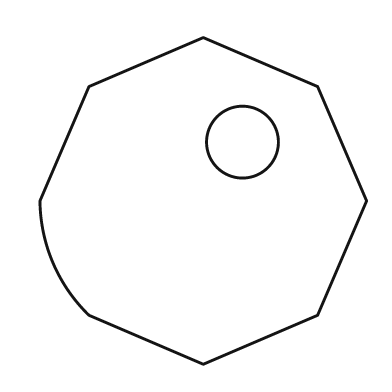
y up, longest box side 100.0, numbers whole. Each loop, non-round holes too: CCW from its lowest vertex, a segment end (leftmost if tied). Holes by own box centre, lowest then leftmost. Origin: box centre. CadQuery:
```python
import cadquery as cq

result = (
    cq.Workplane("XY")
    .moveTo(0.0, -50.0)
    .lineTo(35.0, -35.0)
    .lineTo(50.0, 0.0)
    .lineTo(35.0, 35.0)
    .lineTo(0.0, 50.0)
    .lineTo(-35.0, 35.0)
    .lineTo(-50.0, 0.0)
    .threePointArc((-46.0, -19.0), (-35.0, -35.0))
    .close()
    .moveTo(12.0, 18.0)
    .circle(11.0)
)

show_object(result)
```